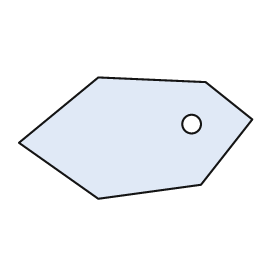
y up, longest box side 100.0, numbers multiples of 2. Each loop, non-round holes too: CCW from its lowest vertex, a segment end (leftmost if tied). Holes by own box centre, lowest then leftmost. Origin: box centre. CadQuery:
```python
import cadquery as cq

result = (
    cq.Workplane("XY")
    .moveTo(-16.0, -26.0)
    .lineTo(28.0, -20.0)
    .lineTo(50.0, 8.0)
    .lineTo(30.0, 24.0)
    .lineTo(-16.0, 26.0)
    .lineTo(-50.0, -2.0)
    .close()
    .moveTo(24.0, 6.0)
    .circle(4.0)
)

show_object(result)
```